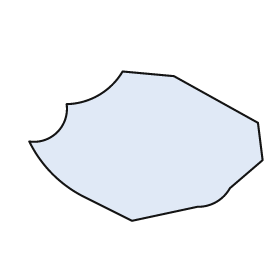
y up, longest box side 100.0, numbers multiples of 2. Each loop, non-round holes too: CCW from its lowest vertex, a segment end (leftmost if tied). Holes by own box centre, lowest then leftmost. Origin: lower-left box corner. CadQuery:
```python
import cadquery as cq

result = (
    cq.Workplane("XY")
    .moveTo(44.0, 0.0)
    .lineTo(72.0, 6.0)
    .threePointArc((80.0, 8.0), (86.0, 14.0))
    .lineTo(100.0, 26.0)
    .lineTo(98.0, 42.0)
    .lineTo(62.0, 62.0)
    .lineTo(40.0, 64.0)
    .threePointArc((30.0, 54.0), (16.0, 50.0))
    .threePointArc((12.0, 38.0), (0.0, 34.0))
    .threePointArc((10.0, 20.0), (24.0, 10.0))
    .close()
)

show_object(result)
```